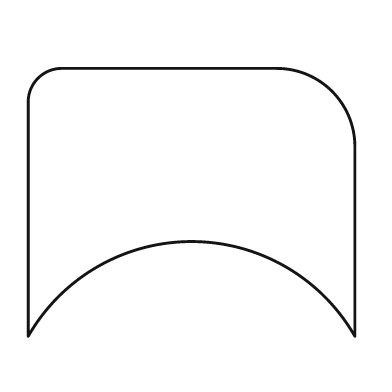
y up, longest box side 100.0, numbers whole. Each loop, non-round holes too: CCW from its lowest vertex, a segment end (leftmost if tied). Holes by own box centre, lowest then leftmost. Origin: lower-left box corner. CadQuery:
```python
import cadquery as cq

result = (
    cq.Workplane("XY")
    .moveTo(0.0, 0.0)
    .threePointArc((50.0, 29.0), (100.0, 0.0))
    .lineTo(100.0, 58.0)
    .threePointArc((93.0, 75.0), (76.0, 82.0))
    .lineTo(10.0, 82.0)
    .threePointArc((3.0, 79.0), (0.0, 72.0))
    .close()
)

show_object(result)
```